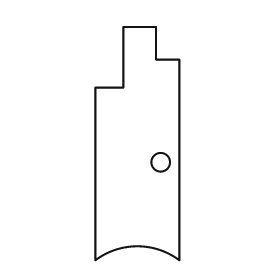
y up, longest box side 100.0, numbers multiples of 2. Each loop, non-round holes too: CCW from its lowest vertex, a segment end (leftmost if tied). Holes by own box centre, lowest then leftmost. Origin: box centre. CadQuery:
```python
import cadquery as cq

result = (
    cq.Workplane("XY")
    .moveTo(-18.0, -50.0)
    .threePointArc((0.0, -44.0), (18.0, -50.0))
    .lineTo(18.0, 36.0)
    .lineTo(8.0, 36.0)
    .lineTo(8.0, 50.0)
    .lineTo(-6.0, 50.0)
    .lineTo(-6.0, 24.0)
    .lineTo(-18.0, 24.0)
    .close()
    .moveTo(10.0, -8.0)
    .circle(4.0)
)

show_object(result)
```